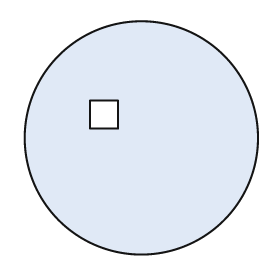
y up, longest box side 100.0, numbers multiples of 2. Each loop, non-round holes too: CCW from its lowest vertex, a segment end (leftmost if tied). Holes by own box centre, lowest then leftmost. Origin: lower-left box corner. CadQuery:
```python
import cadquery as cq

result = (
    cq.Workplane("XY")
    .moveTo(50.0, 50.0)
    .circle(50.0)
    .moveTo(28.0, 54.0)
    .lineTo(40.0, 54.0)
    .lineTo(40.0, 66.0)
    .lineTo(28.0, 66.0)
    .close()
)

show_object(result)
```